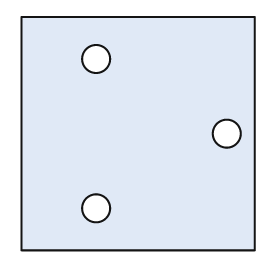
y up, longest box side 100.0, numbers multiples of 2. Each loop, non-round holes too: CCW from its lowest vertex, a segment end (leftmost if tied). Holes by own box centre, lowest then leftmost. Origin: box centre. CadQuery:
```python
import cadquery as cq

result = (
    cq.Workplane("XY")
    .moveTo(-50.0, -50.0)
    .lineTo(50.0, -50.0)
    .lineTo(50.0, 50.0)
    .lineTo(-50.0, 50.0)
    .close()
    .moveTo(-18.0, -32.0)
    .circle(6.0)
    .moveTo(38.0, 0.0)
    .circle(6.0)
    .moveTo(-18.0, 32.0)
    .circle(6.0)
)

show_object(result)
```